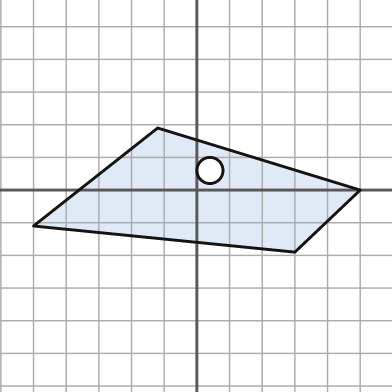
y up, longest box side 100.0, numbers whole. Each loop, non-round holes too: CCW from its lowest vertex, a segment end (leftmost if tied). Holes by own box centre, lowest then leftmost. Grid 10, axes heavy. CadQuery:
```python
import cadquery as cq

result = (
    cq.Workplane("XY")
    .moveTo(30.0, -19.0)
    .lineTo(50.0, 0.0)
    .lineTo(-12.0, 19.0)
    .lineTo(-50.0, -11.0)
    .close()
    .moveTo(4.0, 6.0)
    .circle(4.0)
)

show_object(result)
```